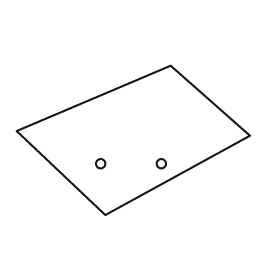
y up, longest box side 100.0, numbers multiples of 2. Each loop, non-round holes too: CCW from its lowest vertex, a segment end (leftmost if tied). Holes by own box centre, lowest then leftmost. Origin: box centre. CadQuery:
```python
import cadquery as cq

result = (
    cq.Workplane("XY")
    .moveTo(-12.0, -32.0)
    .lineTo(50.0, 2.0)
    .lineTo(16.0, 32.0)
    .lineTo(-50.0, 4.0)
    .close()
    .moveTo(-14.0, -10.0)
    .circle(2.0)
    .moveTo(12.0, -10.0)
    .circle(2.0)
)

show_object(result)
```